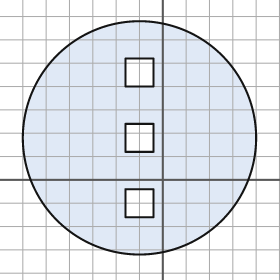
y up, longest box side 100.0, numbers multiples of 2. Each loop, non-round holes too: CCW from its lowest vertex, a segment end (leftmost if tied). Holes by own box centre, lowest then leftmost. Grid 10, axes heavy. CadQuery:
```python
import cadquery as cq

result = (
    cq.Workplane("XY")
    .moveTo(-10.0, 18.0)
    .circle(50.0)
    .moveTo(-16.0, -16.0)
    .lineTo(-4.0, -16.0)
    .lineTo(-4.0, -4.0)
    .lineTo(-16.0, -4.0)
    .close()
    .moveTo(-16.0, 12.0)
    .lineTo(-4.0, 12.0)
    .lineTo(-4.0, 24.0)
    .lineTo(-16.0, 24.0)
    .close()
    .moveTo(-16.0, 40.0)
    .lineTo(-4.0, 40.0)
    .lineTo(-4.0, 52.0)
    .lineTo(-16.0, 52.0)
    .close()
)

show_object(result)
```